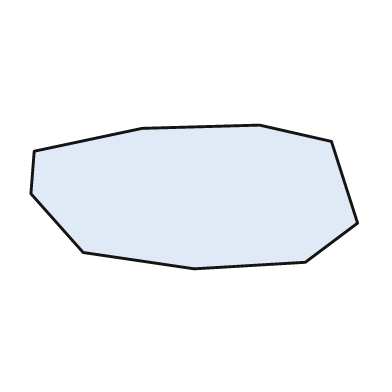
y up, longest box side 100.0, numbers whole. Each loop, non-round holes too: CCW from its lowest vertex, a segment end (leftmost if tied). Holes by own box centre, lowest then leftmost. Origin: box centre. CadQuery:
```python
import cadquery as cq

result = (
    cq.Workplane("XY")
    .moveTo(0.0, -22.0)
    .lineTo(34.0, -20.0)
    .lineTo(50.0, -8.0)
    .lineTo(42.0, 17.0)
    .lineTo(20.0, 22.0)
    .lineTo(-16.0, 21.0)
    .lineTo(-49.0, 14.0)
    .lineTo(-50.0, 1.0)
    .lineTo(-34.0, -17.0)
    .close()
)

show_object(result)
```